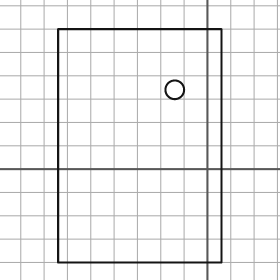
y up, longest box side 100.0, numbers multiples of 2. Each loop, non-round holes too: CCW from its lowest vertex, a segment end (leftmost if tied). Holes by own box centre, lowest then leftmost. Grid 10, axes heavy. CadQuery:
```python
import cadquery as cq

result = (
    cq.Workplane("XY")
    .moveTo(-64.0, -40.0)
    .lineTo(6.0, -40.0)
    .lineTo(6.0, 60.0)
    .lineTo(-64.0, 60.0)
    .close()
    .moveTo(-14.0, 34.0)
    .circle(4.0)
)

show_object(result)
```